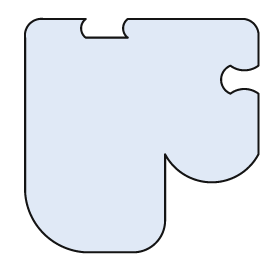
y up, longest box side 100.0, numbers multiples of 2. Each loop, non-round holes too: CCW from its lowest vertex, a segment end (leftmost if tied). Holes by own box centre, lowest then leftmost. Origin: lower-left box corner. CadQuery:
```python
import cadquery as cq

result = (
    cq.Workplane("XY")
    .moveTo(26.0, 0.0)
    .lineTo(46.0, 0.0)
    .threePointArc((56.0, 4.0), (60.0, 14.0))
    .lineTo(60.0, 42.0)
    .threePointArc((80.0, 30.0), (100.0, 42.0))
    .lineTo(100.0, 68.0)
    .threePointArc((94.0, 70.0), (88.0, 68.0))
    .threePointArc((84.0, 74.0), (88.0, 80.0))
    .threePointArc((94.0, 78.0), (100.0, 80.0))
    .lineTo(100.0, 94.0)
    .threePointArc((98.0, 98.0), (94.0, 100.0))
    .lineTo(44.0, 100.0)
    .threePointArc((42.0, 96.0), (44.0, 92.0))
    .lineTo(26.0, 92.0)
    .threePointArc((24.0, 96.0), (26.0, 100.0))
    .lineTo(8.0, 100.0)
    .threePointArc((2.0, 98.0), (0.0, 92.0))
    .lineTo(0.0, 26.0)
    .threePointArc((8.0, 8.0), (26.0, 0.0))
    .close()
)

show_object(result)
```